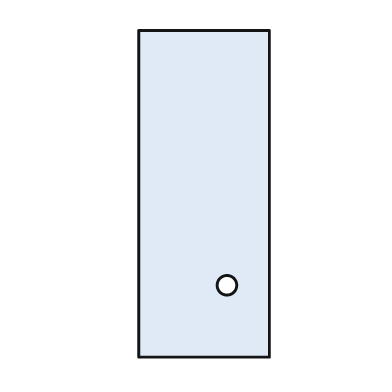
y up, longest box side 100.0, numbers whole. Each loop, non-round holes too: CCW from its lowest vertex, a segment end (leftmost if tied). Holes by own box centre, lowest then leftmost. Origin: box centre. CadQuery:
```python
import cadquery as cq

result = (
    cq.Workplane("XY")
    .moveTo(-20.0, -50.0)
    .lineTo(20.0, -50.0)
    .lineTo(20.0, 50.0)
    .lineTo(-20.0, 50.0)
    .close()
    .moveTo(7.0, -28.0)
    .circle(3.0)
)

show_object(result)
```